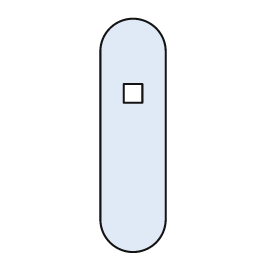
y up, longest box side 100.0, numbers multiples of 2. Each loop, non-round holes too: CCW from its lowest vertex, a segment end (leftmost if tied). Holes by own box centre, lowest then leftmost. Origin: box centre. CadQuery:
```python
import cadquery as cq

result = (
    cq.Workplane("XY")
    .moveTo(-14.0, -36.0)
    .threePointArc((0.0, -50.0), (14.0, -36.0))
    .lineTo(14.0, 36.0)
    .threePointArc((0.0, 50.0), (-14.0, 36.0))
    .close()
    .moveTo(-4.0, 14.0)
    .lineTo(4.0, 14.0)
    .lineTo(4.0, 22.0)
    .lineTo(-4.0, 22.0)
    .close()
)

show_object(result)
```